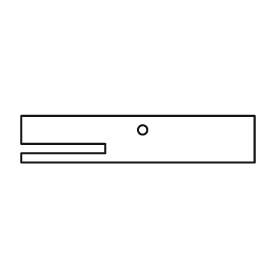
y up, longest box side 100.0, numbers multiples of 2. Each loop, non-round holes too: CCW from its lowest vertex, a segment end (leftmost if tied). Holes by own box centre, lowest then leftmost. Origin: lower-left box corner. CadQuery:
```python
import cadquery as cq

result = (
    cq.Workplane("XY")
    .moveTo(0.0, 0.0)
    .lineTo(100.0, 0.0)
    .lineTo(100.0, 20.0)
    .lineTo(0.0, 20.0)
    .lineTo(0.0, 8.0)
    .lineTo(36.0, 8.0)
    .lineTo(36.0, 4.0)
    .lineTo(0.0, 4.0)
    .close()
    .moveTo(52.0, 14.0)
    .circle(2.0)
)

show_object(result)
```